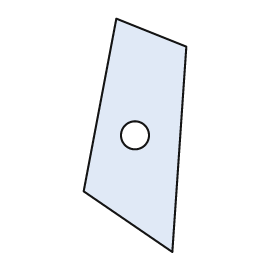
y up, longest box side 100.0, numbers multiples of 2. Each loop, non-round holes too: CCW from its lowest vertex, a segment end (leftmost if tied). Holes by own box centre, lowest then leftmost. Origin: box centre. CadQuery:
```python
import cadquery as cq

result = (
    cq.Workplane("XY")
    .moveTo(16.0, -50.0)
    .lineTo(22.0, 38.0)
    .lineTo(-8.0, 50.0)
    .lineTo(-22.0, -24.0)
    .close()
    .moveTo(0.0, 0.0)
    .circle(6.0)
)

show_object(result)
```